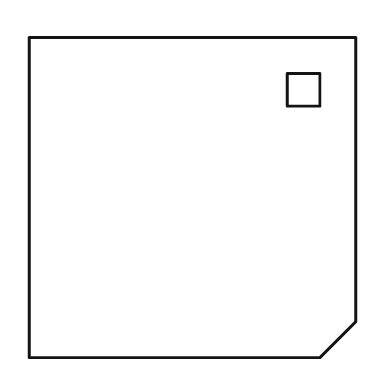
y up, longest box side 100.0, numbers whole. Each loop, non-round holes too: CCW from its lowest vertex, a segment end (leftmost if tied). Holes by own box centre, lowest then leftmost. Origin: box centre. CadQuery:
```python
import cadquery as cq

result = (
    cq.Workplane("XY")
    .moveTo(-50.0, -49.0)
    .lineTo(39.0, -49.0)
    .lineTo(50.0, -38.0)
    .lineTo(50.0, 49.0)
    .lineTo(-50.0, 49.0)
    .close()
    .moveTo(29.0, 28.0)
    .lineTo(39.0, 28.0)
    .lineTo(39.0, 38.0)
    .lineTo(29.0, 38.0)
    .close()
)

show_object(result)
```